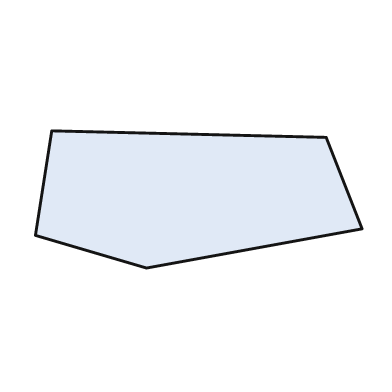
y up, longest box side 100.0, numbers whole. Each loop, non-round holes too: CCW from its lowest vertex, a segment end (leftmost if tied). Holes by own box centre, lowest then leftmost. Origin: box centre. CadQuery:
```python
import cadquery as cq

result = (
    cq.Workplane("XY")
    .moveTo(-16.0, -21.0)
    .lineTo(50.0, -9.0)
    .lineTo(39.0, 19.0)
    .lineTo(-45.0, 21.0)
    .lineTo(-50.0, -11.0)
    .close()
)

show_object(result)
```